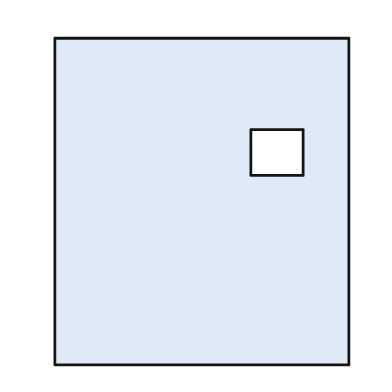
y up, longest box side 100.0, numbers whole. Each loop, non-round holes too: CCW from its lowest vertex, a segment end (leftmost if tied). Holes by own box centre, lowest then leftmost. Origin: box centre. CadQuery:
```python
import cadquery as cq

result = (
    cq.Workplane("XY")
    .moveTo(-45.0, -50.0)
    .lineTo(45.0, -50.0)
    .lineTo(45.0, 50.0)
    .lineTo(-45.0, 50.0)
    .close()
    .moveTo(15.0, 8.0)
    .lineTo(31.0, 8.0)
    .lineTo(31.0, 22.0)
    .lineTo(15.0, 22.0)
    .close()
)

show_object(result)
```